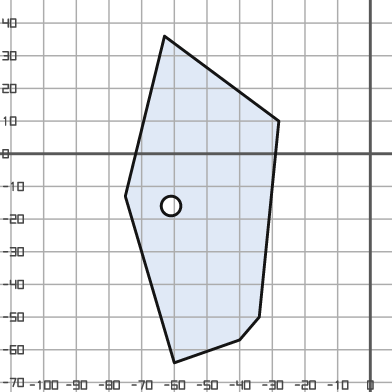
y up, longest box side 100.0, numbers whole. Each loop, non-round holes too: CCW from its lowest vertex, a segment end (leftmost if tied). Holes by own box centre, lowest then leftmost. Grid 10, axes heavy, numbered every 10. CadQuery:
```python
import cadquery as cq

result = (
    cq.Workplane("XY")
    .moveTo(-60.0, -64.0)
    .lineTo(-40.0, -57.0)
    .lineTo(-34.0, -50.0)
    .lineTo(-28.0, 10.0)
    .lineTo(-63.0, 36.0)
    .lineTo(-75.0, -13.0)
    .close()
    .moveTo(-61.0, -16.0)
    .circle(3.0)
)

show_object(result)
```